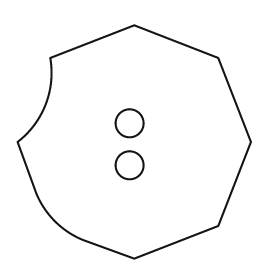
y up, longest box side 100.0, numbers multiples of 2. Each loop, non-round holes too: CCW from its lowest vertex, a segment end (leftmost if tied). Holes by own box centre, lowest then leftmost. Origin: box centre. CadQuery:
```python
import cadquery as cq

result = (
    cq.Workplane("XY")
    .moveTo(0.0, -50.0)
    .lineTo(36.0, -36.0)
    .lineTo(50.0, 0.0)
    .lineTo(36.0, 36.0)
    .lineTo(0.0, 50.0)
    .lineTo(-36.0, 36.0)
    .threePointArc((-38.0, 16.0), (-50.0, 0.0))
    .lineTo(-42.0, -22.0)
    .threePointArc((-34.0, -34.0), (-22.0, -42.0))
    .close()
    .moveTo(-2.0, -10.0)
    .circle(6.0)
    .moveTo(-2.0, 8.0)
    .circle(6.0)
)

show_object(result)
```